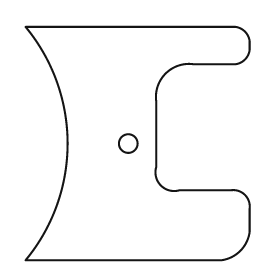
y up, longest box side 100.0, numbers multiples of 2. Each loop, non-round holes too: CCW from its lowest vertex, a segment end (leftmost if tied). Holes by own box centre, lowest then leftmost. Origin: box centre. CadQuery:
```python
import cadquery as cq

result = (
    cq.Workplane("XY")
    .moveTo(-48.0, -50.0)
    .lineTo(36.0, -50.0)
    .threePointArc((44.0, -46.0), (48.0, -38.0))
    .lineTo(48.0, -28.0)
    .threePointArc((46.0, -22.0), (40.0, -20.0))
    .lineTo(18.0, -20.0)
    .threePointArc((10.0, -18.0), (8.0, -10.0))
    .lineTo(8.0, 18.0)
    .threePointArc((12.0, 30.0), (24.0, 34.0))
    .lineTo(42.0, 34.0)
    .threePointArc((46.0, 36.0), (48.0, 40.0))
    .lineTo(48.0, 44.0)
    .threePointArc((46.0, 48.0), (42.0, 50.0))
    .lineTo(-48.0, 50.0)
    .threePointArc((-30.0, 0.0), (-48.0, -50.0))
    .close()
    .moveTo(-4.0, 0.0)
    .circle(4.0)
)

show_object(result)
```